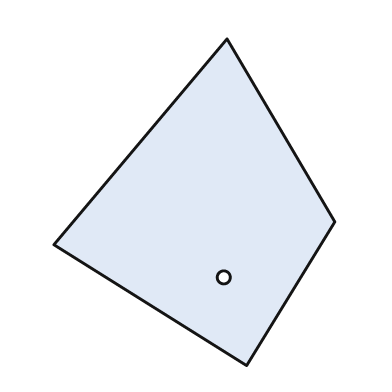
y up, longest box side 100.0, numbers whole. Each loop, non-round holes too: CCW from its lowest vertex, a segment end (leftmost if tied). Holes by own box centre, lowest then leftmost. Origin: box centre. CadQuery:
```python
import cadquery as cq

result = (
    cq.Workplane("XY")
    .moveTo(16.0, -50.0)
    .lineTo(43.0, -6.0)
    .lineTo(10.0, 50.0)
    .lineTo(-43.0, -13.0)
    .close()
    .moveTo(9.0, -23.0)
    .circle(2.0)
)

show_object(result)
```